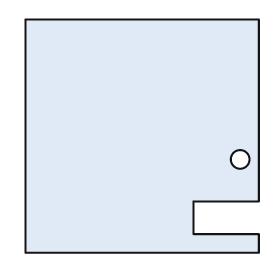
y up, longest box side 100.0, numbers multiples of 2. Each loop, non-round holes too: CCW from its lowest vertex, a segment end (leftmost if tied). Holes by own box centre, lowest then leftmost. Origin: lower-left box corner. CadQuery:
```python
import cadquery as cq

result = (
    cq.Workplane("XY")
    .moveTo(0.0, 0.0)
    .lineTo(100.0, 0.0)
    .lineTo(100.0, 8.0)
    .lineTo(72.0, 8.0)
    .lineTo(72.0, 22.0)
    .lineTo(100.0, 22.0)
    .lineTo(100.0, 100.0)
    .lineTo(0.0, 100.0)
    .close()
    .moveTo(92.0, 40.0)
    .circle(4.0)
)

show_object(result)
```